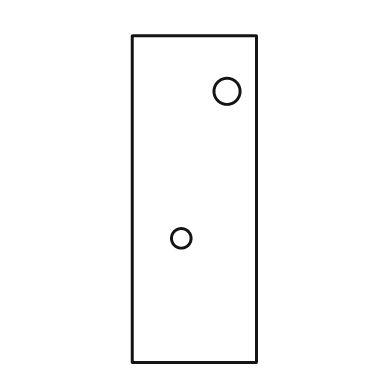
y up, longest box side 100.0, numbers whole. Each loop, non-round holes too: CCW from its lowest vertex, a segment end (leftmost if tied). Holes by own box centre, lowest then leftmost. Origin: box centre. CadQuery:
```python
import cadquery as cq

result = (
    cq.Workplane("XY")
    .moveTo(-19.0, -50.0)
    .lineTo(19.0, -50.0)
    .lineTo(19.0, 50.0)
    .lineTo(-19.0, 50.0)
    .close()
    .moveTo(-4.0, -12.0)
    .circle(3.0)
    .moveTo(10.0, 33.0)
    .circle(4.0)
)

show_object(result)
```